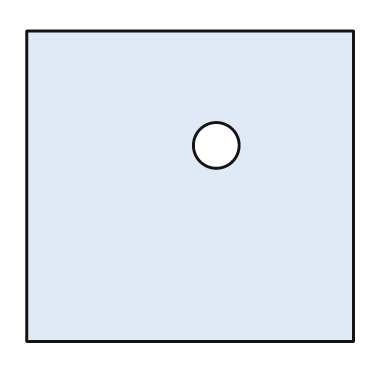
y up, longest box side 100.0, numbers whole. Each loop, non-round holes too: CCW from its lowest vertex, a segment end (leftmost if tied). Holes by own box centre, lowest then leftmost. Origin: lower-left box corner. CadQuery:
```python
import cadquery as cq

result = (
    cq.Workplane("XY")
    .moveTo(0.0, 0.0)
    .lineTo(100.0, 0.0)
    .lineTo(100.0, 95.0)
    .lineTo(0.0, 95.0)
    .close()
    .moveTo(58.0, 60.0)
    .circle(7.0)
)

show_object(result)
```